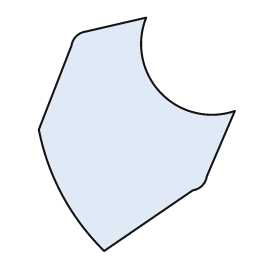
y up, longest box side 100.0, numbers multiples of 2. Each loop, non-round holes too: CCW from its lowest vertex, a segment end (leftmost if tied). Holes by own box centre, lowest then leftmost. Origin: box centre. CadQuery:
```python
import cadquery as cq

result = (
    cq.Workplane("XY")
    .moveTo(-14.0, -50.0)
    .lineTo(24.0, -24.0)
    .threePointArc((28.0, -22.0), (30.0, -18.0))
    .lineTo(42.0, 10.0)
    .threePointArc((10.0, 18.0), (4.0, 50.0))
    .lineTo(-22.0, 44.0)
    .threePointArc((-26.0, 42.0), (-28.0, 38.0))
    .lineTo(-42.0, 2.0)
    .threePointArc((-32.0, -26.0), (-14.0, -50.0))
    .close()
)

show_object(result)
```